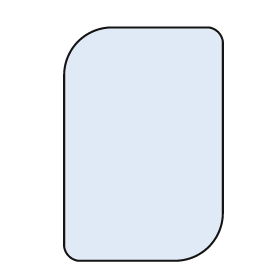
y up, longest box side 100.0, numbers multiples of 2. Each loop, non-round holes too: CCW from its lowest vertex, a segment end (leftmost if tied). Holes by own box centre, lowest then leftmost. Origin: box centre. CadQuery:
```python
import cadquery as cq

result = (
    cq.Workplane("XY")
    .moveTo(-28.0, -50.0)
    .lineTo(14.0, -50.0)
    .threePointArc((28.0, -44.0), (34.0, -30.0))
    .lineTo(34.0, 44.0)
    .threePointArc((32.0, 48.0), (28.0, 50.0))
    .lineTo(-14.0, 50.0)
    .threePointArc((-28.0, 44.0), (-34.0, 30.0))
    .lineTo(-34.0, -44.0)
    .threePointArc((-32.0, -48.0), (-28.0, -50.0))
    .close()
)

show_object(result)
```